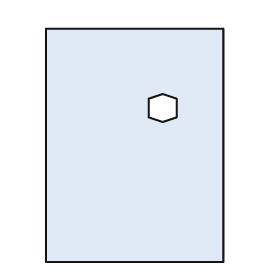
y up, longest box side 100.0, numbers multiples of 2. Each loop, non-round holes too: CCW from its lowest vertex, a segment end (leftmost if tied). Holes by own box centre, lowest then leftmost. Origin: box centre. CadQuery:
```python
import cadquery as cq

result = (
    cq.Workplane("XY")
    .moveTo(-38.0, -50.0)
    .lineTo(38.0, -50.0)
    .lineTo(38.0, 50.0)
    .lineTo(-38.0, 50.0)
    .close()
    .moveTo(12.0, 10.0)
    .lineTo(18.0, 12.0)
    .lineTo(18.0, 20.0)
    .lineTo(12.0, 22.0)
    .lineTo(6.0, 20.0)
    .lineTo(6.0, 12.0)
    .close()
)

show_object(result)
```